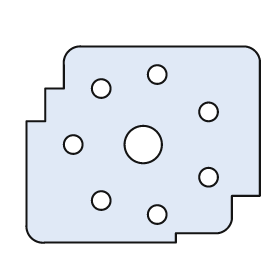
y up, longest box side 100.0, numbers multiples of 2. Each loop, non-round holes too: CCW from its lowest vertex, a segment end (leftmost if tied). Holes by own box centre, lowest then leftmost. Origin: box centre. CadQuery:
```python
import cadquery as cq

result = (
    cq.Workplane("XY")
    .moveTo(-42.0, -42.0)
    .lineTo(14.0, -42.0)
    .lineTo(14.0, -38.0)
    .lineTo(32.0, -38.0)
    .threePointArc((36.0, -36.0), (38.0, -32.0))
    .lineTo(38.0, -22.0)
    .lineTo(50.0, -22.0)
    .lineTo(50.0, 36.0)
    .threePointArc((48.0, 40.0), (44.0, 42.0))
    .lineTo(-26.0, 42.0)
    .threePointArc((-32.0, 40.0), (-34.0, 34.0))
    .lineTo(-34.0, 24.0)
    .lineTo(-42.0, 24.0)
    .lineTo(-42.0, 10.0)
    .lineTo(-50.0, 10.0)
    .lineTo(-50.0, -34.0)
    .threePointArc((-48.0, -40.0), (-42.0, -42.0))
    .close()
    .moveTo(6.0, -30.0)
    .circle(4.0)
    .moveTo(-18.0, -24.0)
    .circle(4.0)
    .moveTo(28.0, -14.0)
    .circle(4.0)
    .moveTo(-30.0, 0.0)
    .circle(4.0)
    .moveTo(0.0, 0.0)
    .circle(8.0)
    .moveTo(28.0, 14.0)
    .circle(4.0)
    .moveTo(-18.0, 24.0)
    .circle(4.0)
    .moveTo(6.0, 30.0)
    .circle(4.0)
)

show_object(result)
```